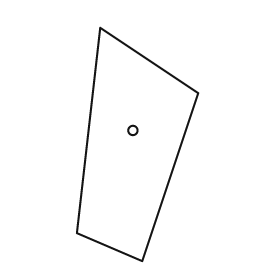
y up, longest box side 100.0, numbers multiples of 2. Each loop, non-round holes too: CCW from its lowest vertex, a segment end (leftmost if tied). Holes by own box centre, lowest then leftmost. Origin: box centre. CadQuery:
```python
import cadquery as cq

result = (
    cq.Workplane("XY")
    .moveTo(2.0, -50.0)
    .lineTo(26.0, 22.0)
    .lineTo(-16.0, 50.0)
    .lineTo(-26.0, -38.0)
    .close()
    .moveTo(-2.0, 6.0)
    .circle(2.0)
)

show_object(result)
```